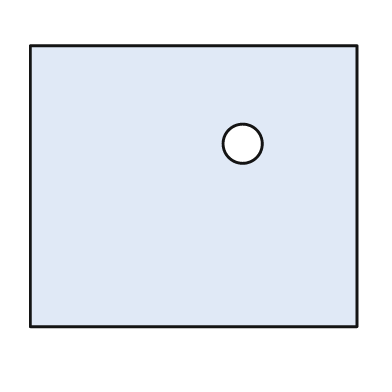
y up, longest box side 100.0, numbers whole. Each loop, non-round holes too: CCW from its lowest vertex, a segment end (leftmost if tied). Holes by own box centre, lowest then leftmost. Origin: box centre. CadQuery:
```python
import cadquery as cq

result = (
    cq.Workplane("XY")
    .moveTo(-50.0, -43.0)
    .lineTo(50.0, -43.0)
    .lineTo(50.0, 43.0)
    .lineTo(-50.0, 43.0)
    .close()
    .moveTo(15.0, 13.0)
    .circle(6.0)
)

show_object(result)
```